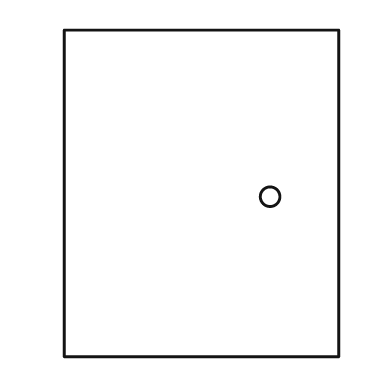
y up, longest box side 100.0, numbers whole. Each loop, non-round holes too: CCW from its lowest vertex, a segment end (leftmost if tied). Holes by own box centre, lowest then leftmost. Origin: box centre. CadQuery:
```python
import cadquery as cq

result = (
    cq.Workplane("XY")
    .moveTo(-42.0, -50.0)
    .lineTo(42.0, -50.0)
    .lineTo(42.0, 50.0)
    .lineTo(-42.0, 50.0)
    .close()
    .moveTo(21.0, -1.0)
    .circle(3.0)
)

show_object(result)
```